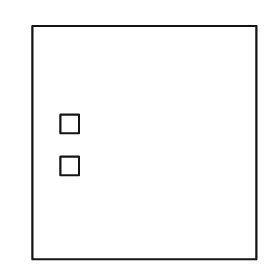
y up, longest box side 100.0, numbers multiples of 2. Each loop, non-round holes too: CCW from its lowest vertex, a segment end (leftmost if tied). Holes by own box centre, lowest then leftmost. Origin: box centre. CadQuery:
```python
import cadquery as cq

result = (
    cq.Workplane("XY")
    .moveTo(-48.0, -50.0)
    .lineTo(48.0, -50.0)
    .lineTo(48.0, 50.0)
    .lineTo(-48.0, 50.0)
    .close()
    .moveTo(-36.0, -14.0)
    .lineTo(-28.0, -14.0)
    .lineTo(-28.0, -6.0)
    .lineTo(-36.0, -6.0)
    .close()
    .moveTo(-36.0, 4.0)
    .lineTo(-28.0, 4.0)
    .lineTo(-28.0, 12.0)
    .lineTo(-36.0, 12.0)
    .close()
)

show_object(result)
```